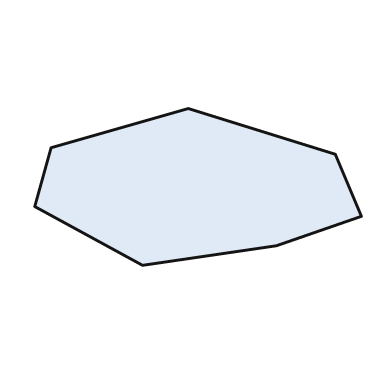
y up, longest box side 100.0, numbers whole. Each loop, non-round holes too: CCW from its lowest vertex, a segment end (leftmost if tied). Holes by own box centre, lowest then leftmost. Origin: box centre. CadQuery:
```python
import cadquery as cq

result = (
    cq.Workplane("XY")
    .moveTo(-17.0, -24.0)
    .lineTo(24.0, -18.0)
    .lineTo(50.0, -9.0)
    .lineTo(42.0, 10.0)
    .lineTo(-3.0, 24.0)
    .lineTo(-45.0, 12.0)
    .lineTo(-50.0, -6.0)
    .close()
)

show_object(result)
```